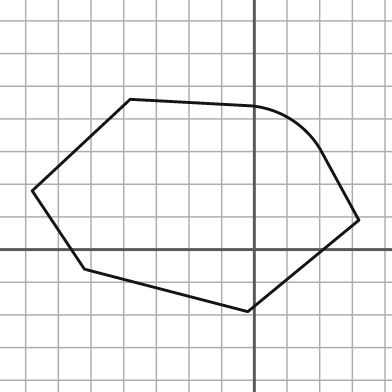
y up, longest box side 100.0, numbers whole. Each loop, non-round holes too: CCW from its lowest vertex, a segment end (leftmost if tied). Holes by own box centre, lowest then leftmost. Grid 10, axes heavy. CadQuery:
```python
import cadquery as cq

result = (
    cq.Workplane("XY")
    .moveTo(-2.0, -19.0)
    .lineTo(32.0, 9.0)
    .lineTo(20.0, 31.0)
    .threePointArc((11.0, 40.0), (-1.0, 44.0))
    .lineTo(-38.0, 46.0)
    .lineTo(-68.0, 18.0)
    .lineTo(-52.0, -6.0)
    .close()
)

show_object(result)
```